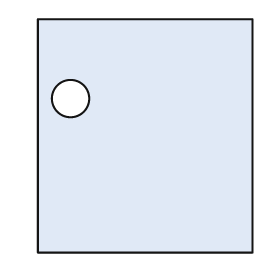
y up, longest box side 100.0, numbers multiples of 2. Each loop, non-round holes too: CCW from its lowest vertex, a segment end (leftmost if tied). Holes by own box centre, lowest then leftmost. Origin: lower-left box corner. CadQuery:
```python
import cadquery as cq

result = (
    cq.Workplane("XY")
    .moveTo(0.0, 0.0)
    .lineTo(92.0, 0.0)
    .lineTo(92.0, 100.0)
    .lineTo(0.0, 100.0)
    .close()
    .moveTo(14.0, 66.0)
    .circle(8.0)
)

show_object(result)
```